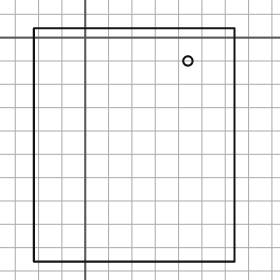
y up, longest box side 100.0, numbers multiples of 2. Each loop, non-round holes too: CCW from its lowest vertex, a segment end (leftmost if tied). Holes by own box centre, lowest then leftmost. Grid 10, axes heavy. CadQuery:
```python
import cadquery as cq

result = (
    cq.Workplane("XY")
    .moveTo(-22.0, -96.0)
    .lineTo(64.0, -96.0)
    .lineTo(64.0, 4.0)
    .lineTo(-22.0, 4.0)
    .close()
    .moveTo(44.0, -10.0)
    .circle(2.0)
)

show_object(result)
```